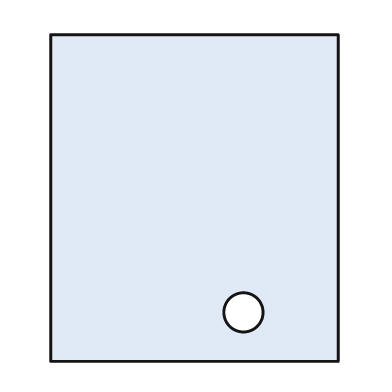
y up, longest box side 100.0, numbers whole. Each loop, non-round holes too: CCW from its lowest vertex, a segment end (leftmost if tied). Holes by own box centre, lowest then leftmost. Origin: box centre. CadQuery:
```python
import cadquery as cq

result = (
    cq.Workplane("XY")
    .moveTo(-44.0, -50.0)
    .lineTo(44.0, -50.0)
    .lineTo(44.0, 50.0)
    .lineTo(-44.0, 50.0)
    .close()
    .moveTo(15.0, -35.0)
    .circle(6.0)
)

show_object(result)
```